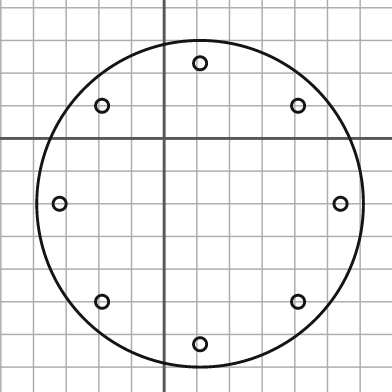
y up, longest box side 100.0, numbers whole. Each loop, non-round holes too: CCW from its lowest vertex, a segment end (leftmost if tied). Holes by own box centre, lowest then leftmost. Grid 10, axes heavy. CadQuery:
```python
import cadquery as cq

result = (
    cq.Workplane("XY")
    .moveTo(11.0, -20.0)
    .circle(50.0)
    .moveTo(11.0, -63.0)
    .circle(2.0)
    .moveTo(-19.0, -50.0)
    .circle(2.0)
    .moveTo(41.0, -50.0)
    .circle(2.0)
    .moveTo(-32.0, -20.0)
    .circle(2.0)
    .moveTo(54.0, -20.0)
    .circle(2.0)
    .moveTo(-19.0, 10.0)
    .circle(2.0)
    .moveTo(41.0, 10.0)
    .circle(2.0)
    .moveTo(11.0, 23.0)
    .circle(2.0)
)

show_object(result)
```